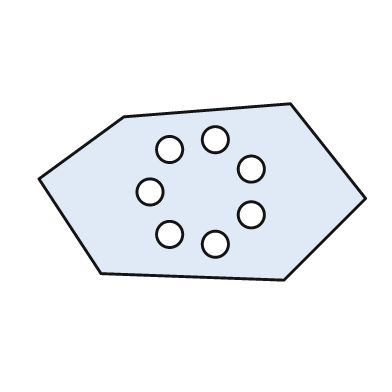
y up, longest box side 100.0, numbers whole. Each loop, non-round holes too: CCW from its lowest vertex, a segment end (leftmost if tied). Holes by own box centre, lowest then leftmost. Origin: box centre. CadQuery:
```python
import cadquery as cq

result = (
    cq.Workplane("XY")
    .moveTo(25.0, -27.0)
    .lineTo(50.0, -2.0)
    .lineTo(27.0, 27.0)
    .lineTo(-24.0, 23.0)
    .lineTo(-50.0, 4.0)
    .lineTo(-31.0, -25.0)
    .close()
    .moveTo(4.0, -16.0)
    .circle(4.0)
    .moveTo(-10.0, -13.0)
    .circle(4.0)
    .moveTo(15.0, -7.0)
    .circle(4.0)
    .moveTo(-16.0, 0.0)
    .circle(4.0)
    .moveTo(15.0, 7.0)
    .circle(4.0)
    .moveTo(-10.0, 13.0)
    .circle(4.0)
    .moveTo(4.0, 16.0)
    .circle(4.0)
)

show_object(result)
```